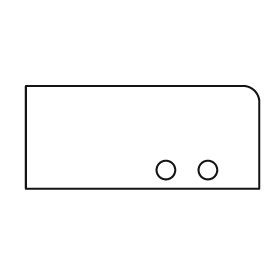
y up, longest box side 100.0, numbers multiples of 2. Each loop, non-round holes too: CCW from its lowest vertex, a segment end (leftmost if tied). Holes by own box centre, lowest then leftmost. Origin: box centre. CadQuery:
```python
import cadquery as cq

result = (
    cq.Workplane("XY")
    .moveTo(-50.0, -22.0)
    .lineTo(50.0, -22.0)
    .lineTo(50.0, 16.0)
    .threePointArc((48.0, 20.0), (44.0, 22.0))
    .lineTo(-50.0, 22.0)
    .close()
    .moveTo(10.0, -14.0)
    .circle(4.0)
    .moveTo(28.0, -14.0)
    .circle(4.0)
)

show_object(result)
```